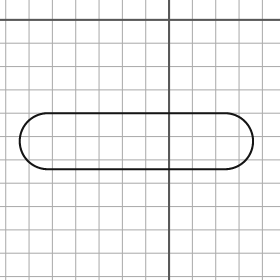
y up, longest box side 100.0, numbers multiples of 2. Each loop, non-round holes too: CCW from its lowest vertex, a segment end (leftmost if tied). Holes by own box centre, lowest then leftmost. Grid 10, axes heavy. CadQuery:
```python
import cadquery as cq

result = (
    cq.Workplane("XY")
    .moveTo(-52.0, -64.0)
    .lineTo(24.0, -64.0)
    .threePointArc((36.0, -52.0), (24.0, -40.0))
    .lineTo(-52.0, -40.0)
    .threePointArc((-64.0, -52.0), (-52.0, -64.0))
    .close()
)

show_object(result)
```